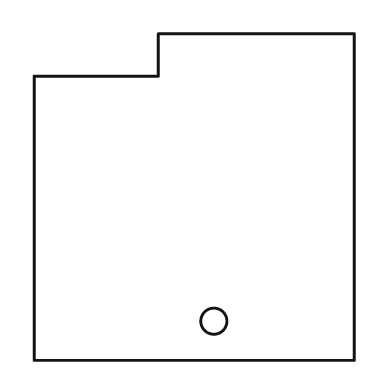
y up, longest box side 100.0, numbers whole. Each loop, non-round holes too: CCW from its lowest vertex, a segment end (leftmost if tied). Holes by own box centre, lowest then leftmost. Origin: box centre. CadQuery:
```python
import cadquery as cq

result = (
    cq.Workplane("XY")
    .moveTo(-49.0, -50.0)
    .lineTo(49.0, -50.0)
    .lineTo(49.0, 50.0)
    .lineTo(-11.0, 50.0)
    .lineTo(-11.0, 37.0)
    .lineTo(-49.0, 37.0)
    .close()
    .moveTo(6.0, -38.0)
    .circle(4.0)
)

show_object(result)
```